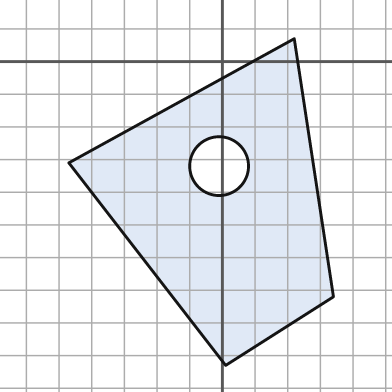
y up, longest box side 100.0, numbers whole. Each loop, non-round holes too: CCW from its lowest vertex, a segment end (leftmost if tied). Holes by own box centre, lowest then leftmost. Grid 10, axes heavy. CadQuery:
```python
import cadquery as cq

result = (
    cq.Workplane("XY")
    .moveTo(1.0, -93.0)
    .lineTo(34.0, -72.0)
    .lineTo(22.0, 7.0)
    .lineTo(-47.0, -31.0)
    .close()
    .moveTo(-1.0, -32.0)
    .circle(9.0)
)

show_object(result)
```